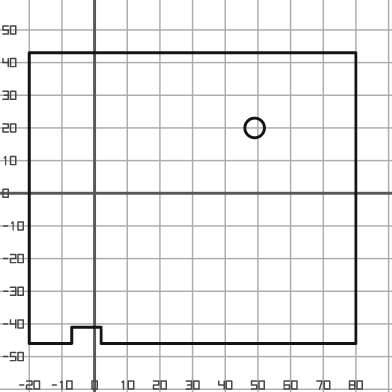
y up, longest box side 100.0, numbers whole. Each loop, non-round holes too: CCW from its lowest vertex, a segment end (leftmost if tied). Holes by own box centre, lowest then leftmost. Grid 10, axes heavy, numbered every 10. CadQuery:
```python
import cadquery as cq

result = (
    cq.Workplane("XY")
    .moveTo(-20.0, -46.0)
    .lineTo(-7.0, -46.0)
    .lineTo(-7.0, -41.0)
    .lineTo(2.0, -41.0)
    .lineTo(2.0, -46.0)
    .lineTo(80.0, -46.0)
    .lineTo(80.0, 43.0)
    .lineTo(-20.0, 43.0)
    .close()
    .moveTo(49.0, 20.0)
    .circle(3.0)
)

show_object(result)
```